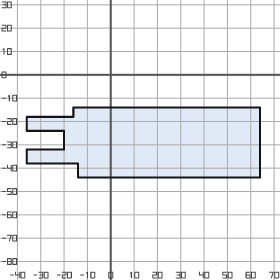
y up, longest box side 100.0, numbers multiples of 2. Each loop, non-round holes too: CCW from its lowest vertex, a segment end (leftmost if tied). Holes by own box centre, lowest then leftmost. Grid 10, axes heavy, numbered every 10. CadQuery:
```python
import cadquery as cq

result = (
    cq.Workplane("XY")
    .moveTo(-14.0, -44.0)
    .lineTo(64.0, -44.0)
    .lineTo(64.0, -14.0)
    .lineTo(-16.0, -14.0)
    .lineTo(-16.0, -18.0)
    .lineTo(-36.0, -18.0)
    .lineTo(-36.0, -24.0)
    .lineTo(-20.0, -24.0)
    .lineTo(-20.0, -32.0)
    .lineTo(-36.0, -32.0)
    .lineTo(-36.0, -38.0)
    .lineTo(-14.0, -38.0)
    .close()
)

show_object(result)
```